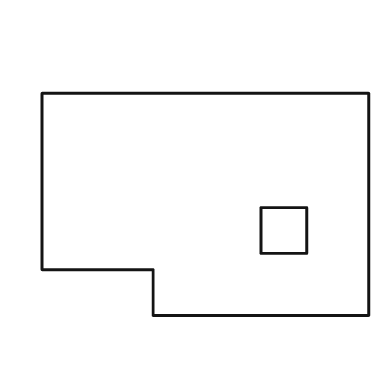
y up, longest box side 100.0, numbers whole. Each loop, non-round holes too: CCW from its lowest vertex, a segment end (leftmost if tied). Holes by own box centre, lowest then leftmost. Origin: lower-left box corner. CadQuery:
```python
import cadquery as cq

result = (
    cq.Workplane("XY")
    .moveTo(34.0, 0.0)
    .lineTo(100.0, 0.0)
    .lineTo(100.0, 68.0)
    .lineTo(0.0, 68.0)
    .lineTo(0.0, 14.0)
    .lineTo(34.0, 14.0)
    .close()
    .moveTo(67.0, 19.0)
    .lineTo(81.0, 19.0)
    .lineTo(81.0, 33.0)
    .lineTo(67.0, 33.0)
    .close()
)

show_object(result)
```